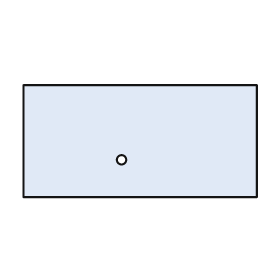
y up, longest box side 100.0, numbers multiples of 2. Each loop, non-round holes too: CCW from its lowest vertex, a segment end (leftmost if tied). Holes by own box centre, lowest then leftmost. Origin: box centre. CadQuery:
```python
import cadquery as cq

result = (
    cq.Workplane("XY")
    .moveTo(-50.0, -24.0)
    .lineTo(50.0, -24.0)
    .lineTo(50.0, 24.0)
    .lineTo(-50.0, 24.0)
    .close()
    .moveTo(-8.0, -8.0)
    .circle(2.0)
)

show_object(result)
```